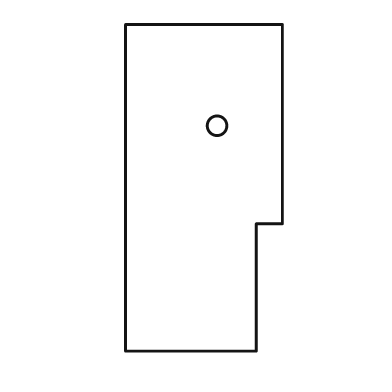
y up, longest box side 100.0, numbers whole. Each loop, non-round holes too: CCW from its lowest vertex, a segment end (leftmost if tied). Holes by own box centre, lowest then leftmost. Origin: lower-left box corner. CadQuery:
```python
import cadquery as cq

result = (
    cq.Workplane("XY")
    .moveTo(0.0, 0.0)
    .lineTo(40.0, 0.0)
    .lineTo(40.0, 39.0)
    .lineTo(48.0, 39.0)
    .lineTo(48.0, 100.0)
    .lineTo(0.0, 100.0)
    .close()
    .moveTo(28.0, 69.0)
    .circle(3.0)
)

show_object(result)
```